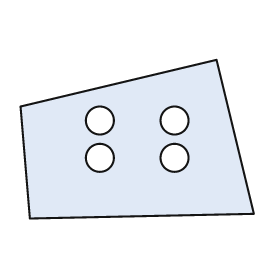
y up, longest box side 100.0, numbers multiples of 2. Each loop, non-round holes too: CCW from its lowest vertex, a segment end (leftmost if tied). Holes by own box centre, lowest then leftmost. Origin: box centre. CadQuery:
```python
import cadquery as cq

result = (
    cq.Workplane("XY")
    .moveTo(-46.0, -34.0)
    .lineTo(50.0, -32.0)
    .lineTo(34.0, 34.0)
    .lineTo(-50.0, 14.0)
    .close()
    .moveTo(-16.0, -8.0)
    .circle(6.0)
    .moveTo(16.0, -8.0)
    .circle(6.0)
    .moveTo(-16.0, 8.0)
    .circle(6.0)
    .moveTo(16.0, 8.0)
    .circle(6.0)
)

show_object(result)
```